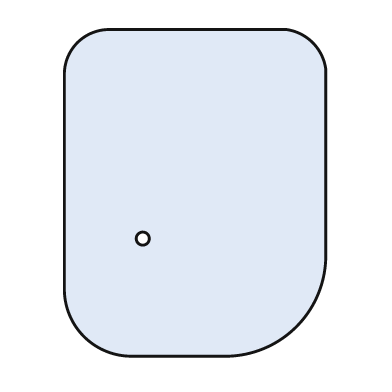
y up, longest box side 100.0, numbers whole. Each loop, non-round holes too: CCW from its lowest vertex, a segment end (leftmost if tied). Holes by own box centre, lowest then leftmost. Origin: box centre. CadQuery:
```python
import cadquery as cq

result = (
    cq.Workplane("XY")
    .moveTo(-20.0, -50.0)
    .lineTo(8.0, -50.0)
    .threePointArc((31.0, -41.0), (40.0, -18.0))
    .lineTo(40.0, 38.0)
    .threePointArc((36.0, 46.0), (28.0, 50.0))
    .lineTo(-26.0, 50.0)
    .threePointArc((-36.0, 46.0), (-40.0, 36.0))
    .lineTo(-40.0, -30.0)
    .threePointArc((-34.0, -44.0), (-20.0, -50.0))
    .close()
    .moveTo(-16.0, -14.0)
    .circle(2.0)
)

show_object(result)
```